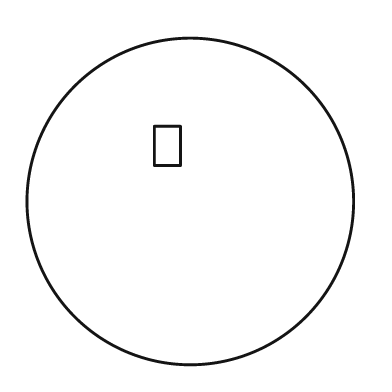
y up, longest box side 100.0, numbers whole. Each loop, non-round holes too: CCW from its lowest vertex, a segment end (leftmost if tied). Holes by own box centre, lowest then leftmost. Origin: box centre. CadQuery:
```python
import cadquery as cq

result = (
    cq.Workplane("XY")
    .moveTo(0.0, 0.0)
    .circle(50.0)
    .moveTo(-11.0, 11.0)
    .lineTo(-3.0, 11.0)
    .lineTo(-3.0, 23.0)
    .lineTo(-11.0, 23.0)
    .close()
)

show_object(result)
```